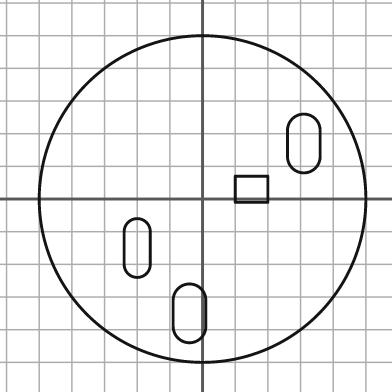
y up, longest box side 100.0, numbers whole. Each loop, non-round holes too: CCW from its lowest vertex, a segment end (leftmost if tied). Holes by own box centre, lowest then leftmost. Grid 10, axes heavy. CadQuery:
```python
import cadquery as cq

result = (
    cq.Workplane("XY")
    .moveTo(0.0, 0.0)
    .circle(50.0)
    .moveTo(-9.0, -39.0)
    .threePointArc((-4.0, -44.0), (1.0, -39.0))
    .lineTo(1.0, -31.0)
    .threePointArc((-4.0, -26.0), (-9.0, -31.0))
    .close()
    .moveTo(-24.0, -20.0)
    .threePointArc((-20.0, -24.0), (-16.0, -20.0))
    .lineTo(-16.0, -10.0)
    .threePointArc((-20.0, -6.0), (-24.0, -10.0))
    .close()
    .moveTo(10.0, -1.0)
    .lineTo(20.0, -1.0)
    .lineTo(20.0, 7.0)
    .lineTo(10.0, 7.0)
    .close()
    .moveTo(26.0, 13.0)
    .threePointArc((31.0, 8.0), (36.0, 13.0))
    .lineTo(36.0, 21.0)
    .threePointArc((31.0, 26.0), (26.0, 21.0))
    .close()
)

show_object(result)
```